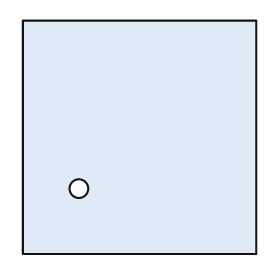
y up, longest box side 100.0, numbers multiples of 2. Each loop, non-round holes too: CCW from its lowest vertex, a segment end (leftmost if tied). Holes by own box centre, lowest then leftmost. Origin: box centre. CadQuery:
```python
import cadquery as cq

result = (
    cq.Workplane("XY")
    .moveTo(-50.0, -50.0)
    .lineTo(50.0, -50.0)
    .lineTo(50.0, 50.0)
    .lineTo(-50.0, 50.0)
    .close()
    .moveTo(-26.0, -22.0)
    .circle(4.0)
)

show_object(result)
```